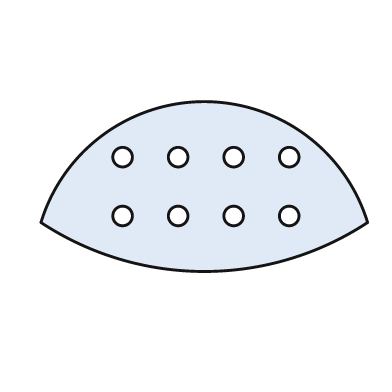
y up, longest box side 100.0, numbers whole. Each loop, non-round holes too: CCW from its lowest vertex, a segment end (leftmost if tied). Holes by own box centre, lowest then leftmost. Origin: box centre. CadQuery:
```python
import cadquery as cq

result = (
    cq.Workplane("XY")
    .moveTo(-50.0, -11.0)
    .threePointArc((0.0, -26.0), (50.0, -11.0))
    .threePointArc((0.0, 26.0), (-50.0, -11.0))
    .close()
    .moveTo(-25.0, -9.0)
    .circle(3.0)
    .moveTo(-8.0, -9.0)
    .circle(3.0)
    .moveTo(9.0, -9.0)
    .circle(3.0)
    .moveTo(26.0, -9.0)
    .circle(3.0)
    .moveTo(-25.0, 9.0)
    .circle(3.0)
    .moveTo(-8.0, 9.0)
    .circle(3.0)
    .moveTo(9.0, 9.0)
    .circle(3.0)
    .moveTo(26.0, 9.0)
    .circle(3.0)
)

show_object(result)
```